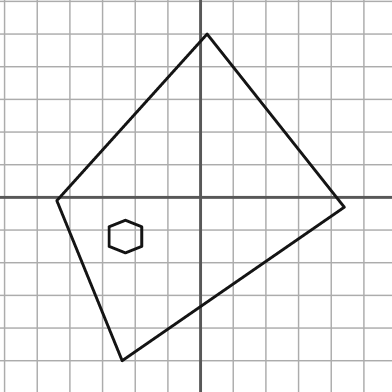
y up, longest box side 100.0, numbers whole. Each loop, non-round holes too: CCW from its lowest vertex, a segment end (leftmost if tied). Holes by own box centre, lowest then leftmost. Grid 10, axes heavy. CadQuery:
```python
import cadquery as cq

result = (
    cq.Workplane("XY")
    .moveTo(-24.0, -50.0)
    .lineTo(44.0, -3.0)
    .lineTo(2.0, 50.0)
    .lineTo(-44.0, -1.0)
    .close()
    .moveTo(-23.0, -17.0)
    .lineTo(-18.0, -15.0)
    .lineTo(-18.0, -9.0)
    .lineTo(-23.0, -7.0)
    .lineTo(-28.0, -9.0)
    .lineTo(-28.0, -15.0)
    .close()
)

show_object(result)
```